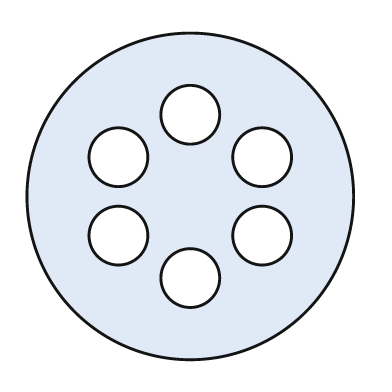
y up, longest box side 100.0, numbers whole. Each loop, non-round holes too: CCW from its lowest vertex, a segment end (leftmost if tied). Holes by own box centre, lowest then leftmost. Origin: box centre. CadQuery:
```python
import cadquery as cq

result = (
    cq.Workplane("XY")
    .moveTo(0.0, 0.0)
    .circle(50.0)
    .moveTo(0.0, -25.0)
    .circle(9.0)
    .moveTo(-22.0, -12.0)
    .circle(9.0)
    .moveTo(22.0, -12.0)
    .circle(9.0)
    .moveTo(-22.0, 12.0)
    .circle(9.0)
    .moveTo(22.0, 12.0)
    .circle(9.0)
    .moveTo(0.0, 25.0)
    .circle(9.0)
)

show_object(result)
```